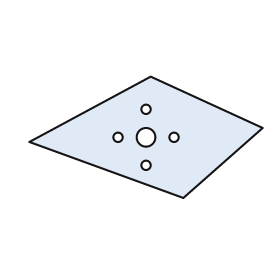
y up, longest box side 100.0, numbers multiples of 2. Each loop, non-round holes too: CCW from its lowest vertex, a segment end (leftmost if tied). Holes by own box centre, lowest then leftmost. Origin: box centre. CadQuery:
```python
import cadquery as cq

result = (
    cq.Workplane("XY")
    .moveTo(16.0, -26.0)
    .lineTo(50.0, 4.0)
    .lineTo(2.0, 26.0)
    .lineTo(-50.0, -2.0)
    .close()
    .moveTo(0.0, -12.0)
    .circle(2.0)
    .moveTo(-12.0, 0.0)
    .circle(2.0)
    .moveTo(0.0, 0.0)
    .circle(4.0)
    .moveTo(12.0, 0.0)
    .circle(2.0)
    .moveTo(0.0, 12.0)
    .circle(2.0)
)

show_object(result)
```